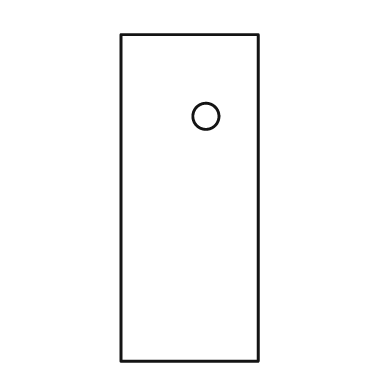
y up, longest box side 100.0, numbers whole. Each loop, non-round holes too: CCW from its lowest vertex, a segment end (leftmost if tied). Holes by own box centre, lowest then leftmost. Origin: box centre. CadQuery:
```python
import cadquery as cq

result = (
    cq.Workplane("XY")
    .moveTo(-21.0, -50.0)
    .lineTo(21.0, -50.0)
    .lineTo(21.0, 50.0)
    .lineTo(-21.0, 50.0)
    .close()
    .moveTo(5.0, 25.0)
    .circle(4.0)
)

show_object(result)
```